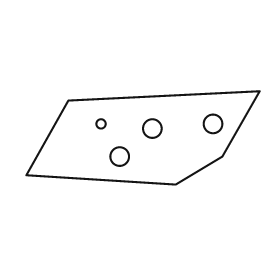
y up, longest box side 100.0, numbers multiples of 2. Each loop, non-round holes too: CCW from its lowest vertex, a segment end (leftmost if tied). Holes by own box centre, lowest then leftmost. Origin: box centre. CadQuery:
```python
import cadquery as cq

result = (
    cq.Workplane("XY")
    .moveTo(14.0, -20.0)
    .lineTo(34.0, -8.0)
    .lineTo(50.0, 20.0)
    .lineTo(-32.0, 16.0)
    .lineTo(-50.0, -16.0)
    .close()
    .moveTo(-10.0, -8.0)
    .circle(4.0)
    .moveTo(4.0, 4.0)
    .circle(4.0)
    .moveTo(-18.0, 6.0)
    .circle(2.0)
    .moveTo(30.0, 6.0)
    .circle(4.0)
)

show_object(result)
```